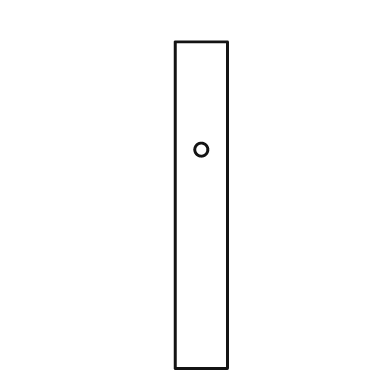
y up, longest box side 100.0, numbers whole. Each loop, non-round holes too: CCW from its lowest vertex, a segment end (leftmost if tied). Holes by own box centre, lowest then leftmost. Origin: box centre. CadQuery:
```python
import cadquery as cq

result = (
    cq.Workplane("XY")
    .moveTo(-8.0, -50.0)
    .lineTo(8.0, -50.0)
    .lineTo(8.0, 50.0)
    .lineTo(-8.0, 50.0)
    .close()
    .moveTo(0.0, 17.0)
    .circle(2.0)
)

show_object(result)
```